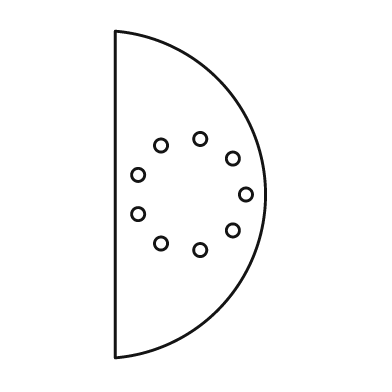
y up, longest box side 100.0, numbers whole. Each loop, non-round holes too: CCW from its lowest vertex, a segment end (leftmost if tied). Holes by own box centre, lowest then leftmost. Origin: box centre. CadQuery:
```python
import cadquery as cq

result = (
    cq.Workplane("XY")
    .moveTo(-23.0, -50.0)
    .threePointArc((23.0, 0.0), (-23.0, 50.0))
    .close()
    .moveTo(3.0, -17.0)
    .circle(2.0)
    .moveTo(-9.0, -15.0)
    .circle(2.0)
    .moveTo(13.0, -11.0)
    .circle(2.0)
    .moveTo(-16.0, -6.0)
    .circle(2.0)
    .moveTo(17.0, 0.0)
    .circle(2.0)
    .moveTo(-16.0, 6.0)
    .circle(2.0)
    .moveTo(13.0, 11.0)
    .circle(2.0)
    .moveTo(-9.0, 15.0)
    .circle(2.0)
    .moveTo(3.0, 17.0)
    .circle(2.0)
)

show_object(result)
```